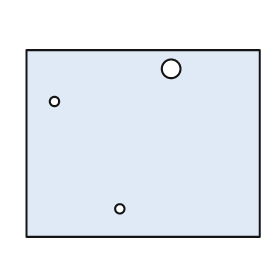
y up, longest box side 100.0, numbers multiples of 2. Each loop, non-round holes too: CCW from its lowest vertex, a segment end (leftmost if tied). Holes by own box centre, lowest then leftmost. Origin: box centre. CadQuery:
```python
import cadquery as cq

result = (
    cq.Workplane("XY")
    .moveTo(-50.0, -40.0)
    .lineTo(50.0, -40.0)
    .lineTo(50.0, 40.0)
    .lineTo(-50.0, 40.0)
    .close()
    .moveTo(-10.0, -28.0)
    .circle(2.0)
    .moveTo(-38.0, 18.0)
    .circle(2.0)
    .moveTo(12.0, 32.0)
    .circle(4.0)
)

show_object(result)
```